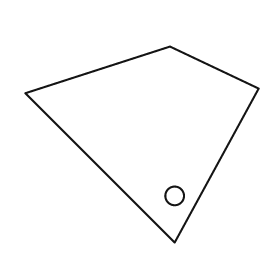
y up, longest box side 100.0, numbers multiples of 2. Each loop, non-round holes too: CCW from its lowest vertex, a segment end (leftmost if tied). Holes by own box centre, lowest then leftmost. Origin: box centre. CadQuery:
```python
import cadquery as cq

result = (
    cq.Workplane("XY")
    .moveTo(14.0, -42.0)
    .lineTo(50.0, 24.0)
    .lineTo(12.0, 42.0)
    .lineTo(-50.0, 22.0)
    .close()
    .moveTo(14.0, -22.0)
    .circle(4.0)
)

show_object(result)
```